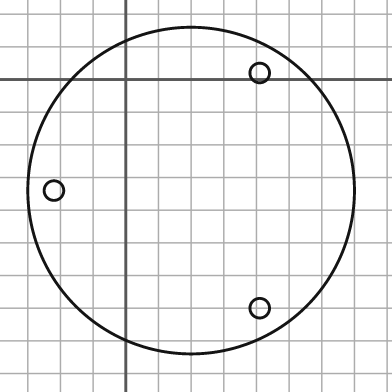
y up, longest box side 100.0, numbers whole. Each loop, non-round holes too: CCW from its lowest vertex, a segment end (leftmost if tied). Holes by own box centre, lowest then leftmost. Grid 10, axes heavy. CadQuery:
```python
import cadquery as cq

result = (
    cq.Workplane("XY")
    .moveTo(20.0, -34.0)
    .circle(50.0)
    .moveTo(41.0, -70.0)
    .circle(3.0)
    .moveTo(-22.0, -34.0)
    .circle(3.0)
    .moveTo(41.0, 2.0)
    .circle(3.0)
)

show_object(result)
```